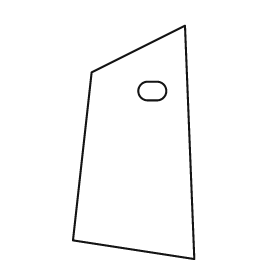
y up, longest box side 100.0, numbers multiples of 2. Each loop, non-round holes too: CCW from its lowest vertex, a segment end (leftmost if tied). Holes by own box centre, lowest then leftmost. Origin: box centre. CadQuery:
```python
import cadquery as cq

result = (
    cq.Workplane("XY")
    .moveTo(26.0, -50.0)
    .lineTo(22.0, 50.0)
    .lineTo(-18.0, 30.0)
    .lineTo(-26.0, -42.0)
    .close()
    .moveTo(6.0, 18.0)
    .lineTo(10.0, 18.0)
    .threePointArc((14.0, 22.0), (10.0, 26.0))
    .lineTo(6.0, 26.0)
    .threePointArc((2.0, 22.0), (6.0, 18.0))
    .close()
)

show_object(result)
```